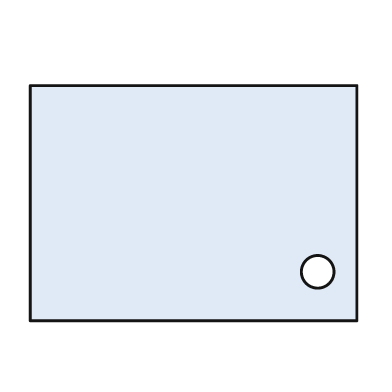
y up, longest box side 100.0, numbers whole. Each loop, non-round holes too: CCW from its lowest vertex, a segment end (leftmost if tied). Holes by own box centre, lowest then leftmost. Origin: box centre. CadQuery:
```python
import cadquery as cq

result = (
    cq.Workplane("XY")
    .moveTo(-50.0, -36.0)
    .lineTo(50.0, -36.0)
    .lineTo(50.0, 36.0)
    .lineTo(-50.0, 36.0)
    .close()
    .moveTo(38.0, -21.0)
    .circle(5.0)
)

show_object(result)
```